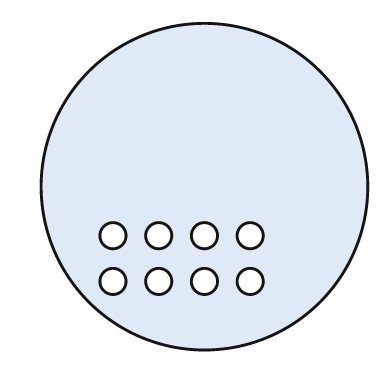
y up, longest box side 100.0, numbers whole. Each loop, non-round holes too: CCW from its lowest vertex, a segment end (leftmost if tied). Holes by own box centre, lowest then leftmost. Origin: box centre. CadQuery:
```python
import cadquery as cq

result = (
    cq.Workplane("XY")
    .moveTo(0.0, 0.0)
    .circle(50.0)
    .moveTo(-28.0, -29.0)
    .circle(4.0)
    .moveTo(-14.0, -29.0)
    .circle(4.0)
    .moveTo(0.0, -29.0)
    .circle(4.0)
    .moveTo(14.0, -29.0)
    .circle(4.0)
    .moveTo(-28.0, -15.0)
    .circle(4.0)
    .moveTo(-14.0, -15.0)
    .circle(4.0)
    .moveTo(0.0, -15.0)
    .circle(4.0)
    .moveTo(14.0, -15.0)
    .circle(4.0)
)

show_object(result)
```